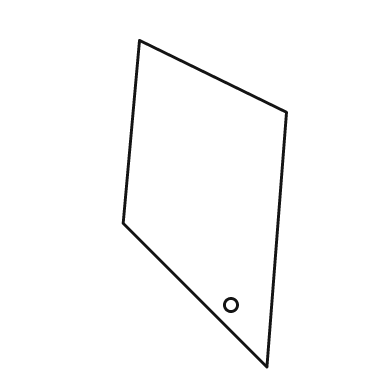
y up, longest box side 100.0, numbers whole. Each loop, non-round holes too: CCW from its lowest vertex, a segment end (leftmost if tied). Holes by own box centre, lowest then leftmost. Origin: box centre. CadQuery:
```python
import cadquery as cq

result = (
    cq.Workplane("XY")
    .moveTo(19.0, -50.0)
    .lineTo(25.0, 28.0)
    .lineTo(-20.0, 50.0)
    .lineTo(-25.0, -6.0)
    .close()
    .moveTo(8.0, -31.0)
    .circle(2.0)
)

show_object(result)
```